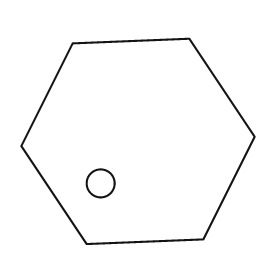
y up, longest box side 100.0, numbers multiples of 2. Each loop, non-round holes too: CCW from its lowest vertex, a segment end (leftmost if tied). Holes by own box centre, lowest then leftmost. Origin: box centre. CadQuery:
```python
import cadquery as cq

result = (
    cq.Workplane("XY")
    .moveTo(-22.0, -44.0)
    .lineTo(28.0, -42.0)
    .lineTo(50.0, 2.0)
    .lineTo(22.0, 44.0)
    .lineTo(-28.0, 42.0)
    .lineTo(-50.0, -2.0)
    .close()
    .moveTo(-16.0, -18.0)
    .circle(6.0)
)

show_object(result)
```